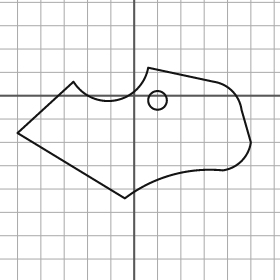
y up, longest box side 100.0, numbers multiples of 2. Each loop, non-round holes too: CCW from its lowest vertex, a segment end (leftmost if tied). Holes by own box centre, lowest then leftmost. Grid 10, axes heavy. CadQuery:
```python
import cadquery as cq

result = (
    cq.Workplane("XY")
    .moveTo(-4.0, -44.0)
    .threePointArc((16.0, -34.0), (38.0, -32.0))
    .threePointArc((46.0, -28.0), (50.0, -20.0))
    .lineTo(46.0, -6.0)
    .threePointArc((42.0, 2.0), (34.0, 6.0))
    .lineTo(6.0, 12.0)
    .threePointArc((-8.0, -2.0), (-26.0, 6.0))
    .lineTo(-50.0, -16.0)
    .close()
    .moveTo(10.0, -2.0)
    .circle(4.0)
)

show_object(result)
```